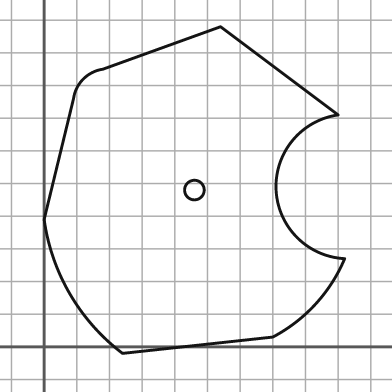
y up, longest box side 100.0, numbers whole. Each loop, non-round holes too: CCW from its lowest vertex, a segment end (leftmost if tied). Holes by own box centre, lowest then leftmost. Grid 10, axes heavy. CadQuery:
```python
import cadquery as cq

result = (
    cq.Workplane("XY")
    .moveTo(24.0, -2.0)
    .lineTo(70.0, 3.0)
    .threePointArc((83.0, 13.0), (92.0, 27.0))
    .threePointArc((71.0, 48.0), (90.0, 71.0))
    .lineTo(54.0, 98.0)
    .lineTo(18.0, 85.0)
    .threePointArc((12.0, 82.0), (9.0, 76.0))
    .lineTo(0.0, 39.0)
    .threePointArc((8.0, 16.0), (24.0, -2.0))
    .close()
    .moveTo(46.0, 48.0)
    .circle(3.0)
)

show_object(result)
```